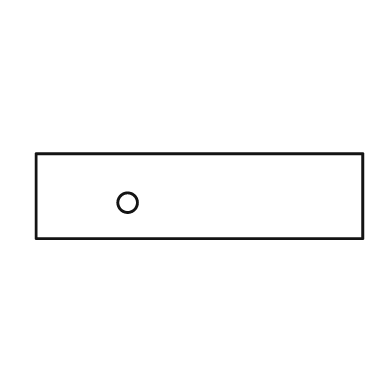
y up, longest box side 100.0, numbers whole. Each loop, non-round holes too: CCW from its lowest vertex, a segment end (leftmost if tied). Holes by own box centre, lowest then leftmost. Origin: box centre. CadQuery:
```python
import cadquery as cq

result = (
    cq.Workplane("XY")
    .moveTo(-50.0, -13.0)
    .lineTo(50.0, -13.0)
    .lineTo(50.0, 13.0)
    .lineTo(-50.0, 13.0)
    .close()
    .moveTo(-22.0, -2.0)
    .circle(3.0)
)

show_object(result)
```